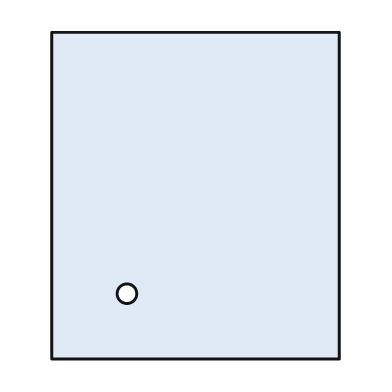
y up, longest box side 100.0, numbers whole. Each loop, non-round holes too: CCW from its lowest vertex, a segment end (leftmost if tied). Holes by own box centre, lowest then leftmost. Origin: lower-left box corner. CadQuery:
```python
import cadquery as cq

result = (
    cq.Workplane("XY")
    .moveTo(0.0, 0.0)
    .lineTo(88.0, 0.0)
    .lineTo(88.0, 100.0)
    .lineTo(0.0, 100.0)
    .close()
    .moveTo(23.0, 20.0)
    .circle(3.0)
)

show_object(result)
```